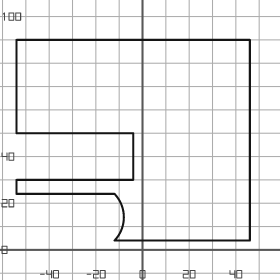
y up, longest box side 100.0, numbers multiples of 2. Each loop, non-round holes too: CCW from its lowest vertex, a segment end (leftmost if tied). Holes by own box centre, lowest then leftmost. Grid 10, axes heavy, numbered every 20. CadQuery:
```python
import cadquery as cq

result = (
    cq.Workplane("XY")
    .moveTo(-12.0, 4.0)
    .lineTo(46.0, 4.0)
    .lineTo(46.0, 90.0)
    .lineTo(-54.0, 90.0)
    .lineTo(-54.0, 50.0)
    .lineTo(-4.0, 50.0)
    .lineTo(-4.0, 30.0)
    .lineTo(-54.0, 30.0)
    .lineTo(-54.0, 24.0)
    .lineTo(-12.0, 24.0)
    .threePointArc((-8.0, 14.0), (-12.0, 4.0))
    .close()
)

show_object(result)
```